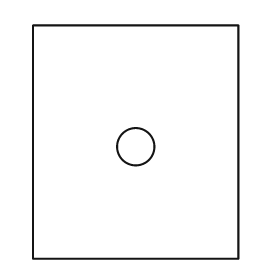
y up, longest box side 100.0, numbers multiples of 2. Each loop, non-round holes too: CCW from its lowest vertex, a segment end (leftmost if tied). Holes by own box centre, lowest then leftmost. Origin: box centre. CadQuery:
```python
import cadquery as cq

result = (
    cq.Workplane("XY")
    .moveTo(-44.0, -50.0)
    .lineTo(44.0, -50.0)
    .lineTo(44.0, 50.0)
    .lineTo(-44.0, 50.0)
    .close()
    .moveTo(0.0, -2.0)
    .circle(8.0)
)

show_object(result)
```